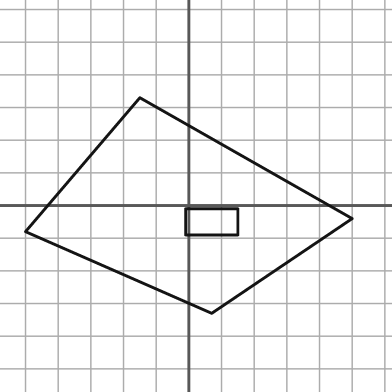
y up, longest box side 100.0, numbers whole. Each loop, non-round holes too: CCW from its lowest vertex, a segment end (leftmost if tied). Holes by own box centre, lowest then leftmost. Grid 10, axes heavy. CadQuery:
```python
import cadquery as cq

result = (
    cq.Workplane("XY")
    .moveTo(7.0, -33.0)
    .lineTo(50.0, -4.0)
    .lineTo(-15.0, 33.0)
    .lineTo(-50.0, -8.0)
    .close()
    .moveTo(-1.0, -9.0)
    .lineTo(15.0, -9.0)
    .lineTo(15.0, -1.0)
    .lineTo(-1.0, -1.0)
    .close()
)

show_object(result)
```